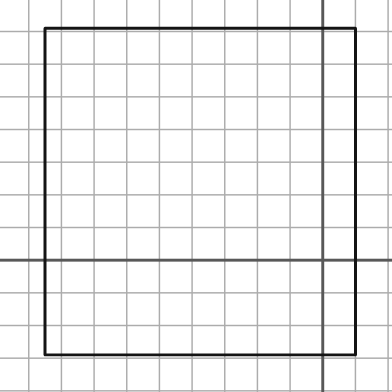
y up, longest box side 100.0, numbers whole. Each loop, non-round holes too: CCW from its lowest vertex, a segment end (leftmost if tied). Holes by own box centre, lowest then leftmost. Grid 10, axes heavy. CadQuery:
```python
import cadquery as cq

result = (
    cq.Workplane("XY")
    .moveTo(-85.0, -29.0)
    .lineTo(10.0, -29.0)
    .lineTo(10.0, 71.0)
    .lineTo(-85.0, 71.0)
    .close()
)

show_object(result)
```